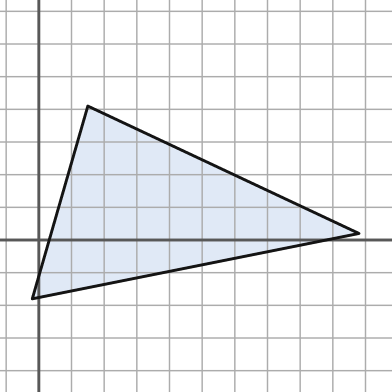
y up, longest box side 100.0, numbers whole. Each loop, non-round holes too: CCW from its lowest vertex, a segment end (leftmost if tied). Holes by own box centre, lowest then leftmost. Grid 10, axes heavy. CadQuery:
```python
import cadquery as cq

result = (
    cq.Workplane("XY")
    .moveTo(-2.0, -18.0)
    .lineTo(98.0, 2.0)
    .lineTo(15.0, 41.0)
    .close()
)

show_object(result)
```